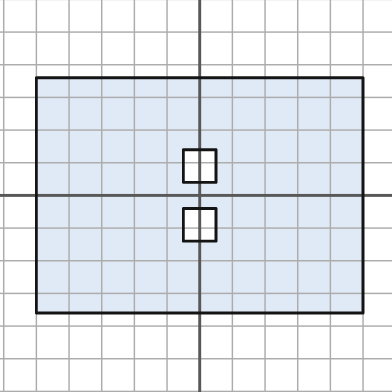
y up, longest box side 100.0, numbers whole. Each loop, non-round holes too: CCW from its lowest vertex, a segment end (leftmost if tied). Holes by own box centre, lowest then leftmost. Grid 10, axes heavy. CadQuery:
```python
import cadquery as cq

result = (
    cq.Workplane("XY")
    .moveTo(-50.0, -36.0)
    .lineTo(50.0, -36.0)
    .lineTo(50.0, 36.0)
    .lineTo(-50.0, 36.0)
    .close()
    .moveTo(-5.0, -14.0)
    .lineTo(5.0, -14.0)
    .lineTo(5.0, -4.0)
    .lineTo(-5.0, -4.0)
    .close()
    .moveTo(-5.0, 4.0)
    .lineTo(5.0, 4.0)
    .lineTo(5.0, 14.0)
    .lineTo(-5.0, 14.0)
    .close()
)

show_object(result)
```